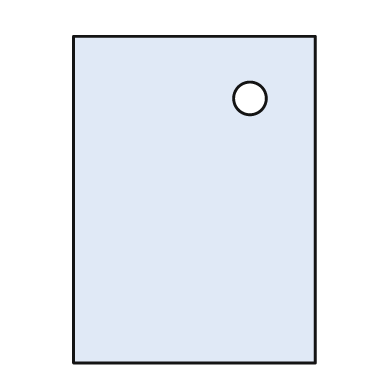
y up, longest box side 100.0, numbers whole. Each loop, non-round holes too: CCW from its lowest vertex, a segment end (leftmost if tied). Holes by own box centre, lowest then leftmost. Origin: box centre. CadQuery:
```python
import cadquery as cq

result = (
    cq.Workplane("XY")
    .moveTo(-37.0, -50.0)
    .lineTo(37.0, -50.0)
    .lineTo(37.0, 50.0)
    .lineTo(-37.0, 50.0)
    .close()
    .moveTo(17.0, 31.0)
    .circle(5.0)
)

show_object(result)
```